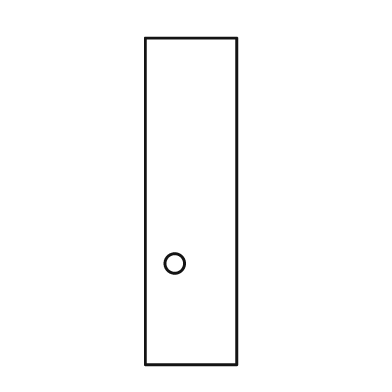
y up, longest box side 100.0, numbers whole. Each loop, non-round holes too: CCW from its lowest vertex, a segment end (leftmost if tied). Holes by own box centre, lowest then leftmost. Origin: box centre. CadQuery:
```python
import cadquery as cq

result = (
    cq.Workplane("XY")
    .moveTo(-14.0, -50.0)
    .lineTo(14.0, -50.0)
    .lineTo(14.0, 50.0)
    .lineTo(-14.0, 50.0)
    .close()
    .moveTo(-5.0, -19.0)
    .circle(3.0)
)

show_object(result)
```